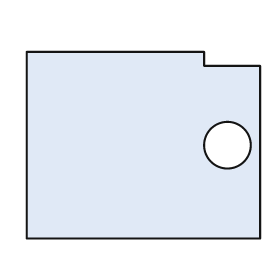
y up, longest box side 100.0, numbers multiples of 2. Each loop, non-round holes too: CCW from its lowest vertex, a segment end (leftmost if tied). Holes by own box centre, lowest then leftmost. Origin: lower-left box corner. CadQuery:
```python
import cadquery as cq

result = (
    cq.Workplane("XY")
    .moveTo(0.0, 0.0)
    .lineTo(100.0, 0.0)
    .lineTo(100.0, 74.0)
    .lineTo(76.0, 74.0)
    .lineTo(76.0, 80.0)
    .lineTo(0.0, 80.0)
    .close()
    .moveTo(86.0, 40.0)
    .circle(10.0)
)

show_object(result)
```